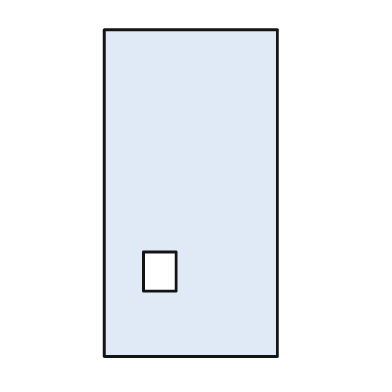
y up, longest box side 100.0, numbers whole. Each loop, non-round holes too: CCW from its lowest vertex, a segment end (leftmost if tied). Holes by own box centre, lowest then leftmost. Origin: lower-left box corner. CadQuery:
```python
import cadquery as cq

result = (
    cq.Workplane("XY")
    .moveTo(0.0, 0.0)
    .lineTo(53.0, 0.0)
    .lineTo(53.0, 100.0)
    .lineTo(0.0, 100.0)
    .close()
    .moveTo(12.0, 20.0)
    .lineTo(22.0, 20.0)
    .lineTo(22.0, 32.0)
    .lineTo(12.0, 32.0)
    .close()
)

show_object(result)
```